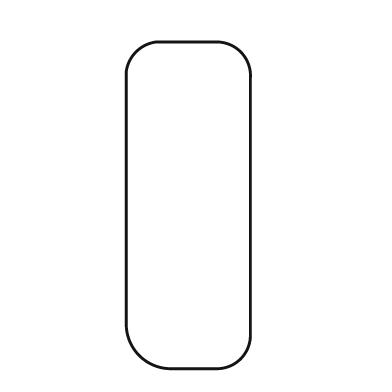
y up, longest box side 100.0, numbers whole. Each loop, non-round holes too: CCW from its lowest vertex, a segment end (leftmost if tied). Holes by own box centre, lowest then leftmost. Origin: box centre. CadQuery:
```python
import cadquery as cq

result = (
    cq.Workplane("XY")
    .moveTo(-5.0, -50.0)
    .lineTo(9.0, -50.0)
    .threePointArc((16.0, -47.0), (19.0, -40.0))
    .lineTo(19.0, 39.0)
    .threePointArc((16.0, 47.0), (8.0, 50.0))
    .lineTo(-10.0, 50.0)
    .threePointArc((-16.0, 47.0), (-19.0, 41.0))
    .lineTo(-19.0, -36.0)
    .threePointArc((-15.0, -46.0), (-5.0, -50.0))
    .close()
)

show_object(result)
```